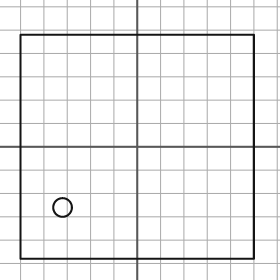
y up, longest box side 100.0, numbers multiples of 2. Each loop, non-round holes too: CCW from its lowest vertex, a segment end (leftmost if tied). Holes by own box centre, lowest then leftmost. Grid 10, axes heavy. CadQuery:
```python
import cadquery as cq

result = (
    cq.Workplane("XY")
    .moveTo(-50.0, -48.0)
    .lineTo(50.0, -48.0)
    .lineTo(50.0, 48.0)
    .lineTo(-50.0, 48.0)
    .close()
    .moveTo(-32.0, -26.0)
    .circle(4.0)
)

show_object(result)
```